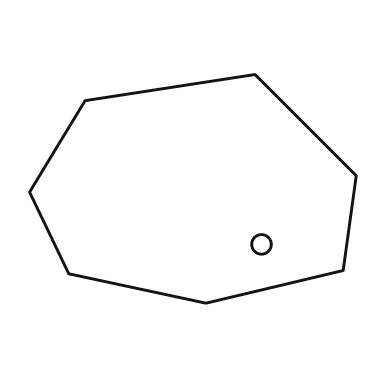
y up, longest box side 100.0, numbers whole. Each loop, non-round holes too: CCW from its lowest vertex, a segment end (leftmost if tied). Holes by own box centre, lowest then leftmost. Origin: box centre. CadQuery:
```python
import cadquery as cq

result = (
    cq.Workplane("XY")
    .moveTo(4.0, -35.0)
    .lineTo(46.0, -25.0)
    .lineTo(50.0, 4.0)
    .lineTo(19.0, 35.0)
    .lineTo(-33.0, 27.0)
    .lineTo(-50.0, -1.0)
    .lineTo(-38.0, -26.0)
    .close()
    .moveTo(21.0, -17.0)
    .circle(3.0)
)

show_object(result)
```